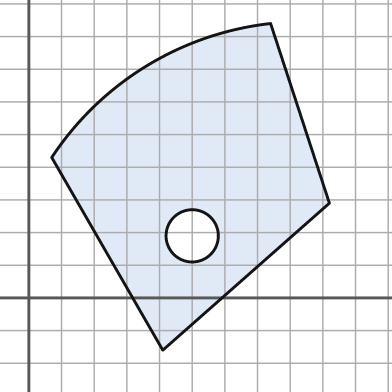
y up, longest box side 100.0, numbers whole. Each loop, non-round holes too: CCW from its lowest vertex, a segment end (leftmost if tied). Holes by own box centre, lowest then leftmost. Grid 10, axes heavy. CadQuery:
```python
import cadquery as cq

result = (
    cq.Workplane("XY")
    .moveTo(41.0, -16.0)
    .lineTo(92.0, 29.0)
    .lineTo(74.0, 84.0)
    .threePointArc((36.0, 71.0), (7.0, 43.0))
    .close()
    .moveTo(50.0, 19.0)
    .circle(8.0)
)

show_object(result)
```